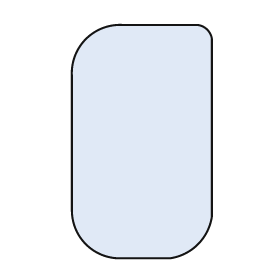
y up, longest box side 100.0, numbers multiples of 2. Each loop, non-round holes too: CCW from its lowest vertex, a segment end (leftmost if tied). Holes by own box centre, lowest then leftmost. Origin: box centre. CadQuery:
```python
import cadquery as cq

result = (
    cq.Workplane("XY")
    .moveTo(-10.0, -50.0)
    .lineTo(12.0, -50.0)
    .threePointArc((24.0, -44.0), (30.0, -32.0))
    .lineTo(30.0, 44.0)
    .threePointArc((28.0, 48.0), (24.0, 50.0))
    .lineTo(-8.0, 50.0)
    .threePointArc((-24.0, 44.0), (-30.0, 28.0))
    .lineTo(-30.0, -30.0)
    .threePointArc((-24.0, -44.0), (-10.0, -50.0))
    .close()
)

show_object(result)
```